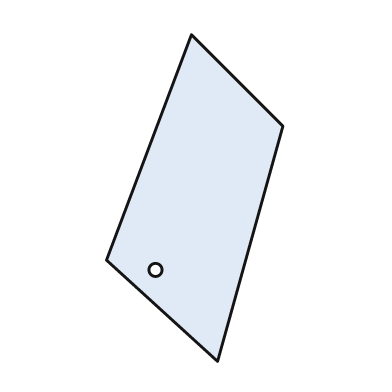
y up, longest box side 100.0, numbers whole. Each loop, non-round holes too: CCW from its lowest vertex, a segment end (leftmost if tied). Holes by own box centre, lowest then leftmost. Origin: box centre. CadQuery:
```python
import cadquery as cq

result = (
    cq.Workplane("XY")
    .moveTo(7.0, -50.0)
    .lineTo(27.0, 22.0)
    .lineTo(-1.0, 50.0)
    .lineTo(-27.0, -19.0)
    .close()
    .moveTo(-12.0, -22.0)
    .circle(2.0)
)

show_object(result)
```